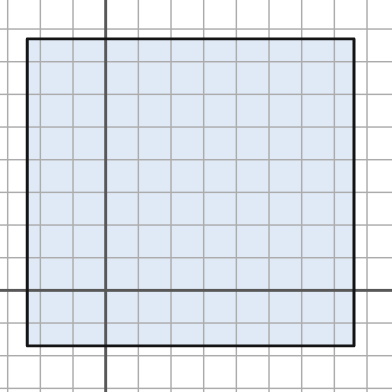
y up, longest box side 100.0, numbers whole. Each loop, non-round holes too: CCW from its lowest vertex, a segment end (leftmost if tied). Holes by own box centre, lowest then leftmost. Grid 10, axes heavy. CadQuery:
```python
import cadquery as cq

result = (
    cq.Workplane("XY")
    .moveTo(-24.0, -17.0)
    .lineTo(76.0, -17.0)
    .lineTo(76.0, 77.0)
    .lineTo(-24.0, 77.0)
    .close()
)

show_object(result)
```